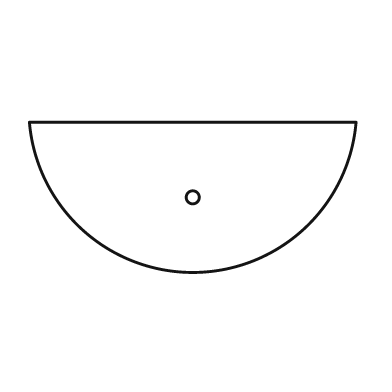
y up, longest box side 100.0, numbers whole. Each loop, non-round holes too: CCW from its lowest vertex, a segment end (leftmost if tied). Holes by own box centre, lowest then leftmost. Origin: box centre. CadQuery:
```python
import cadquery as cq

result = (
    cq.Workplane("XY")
    .moveTo(-50.0, 23.0)
    .threePointArc((0.0, -23.0), (50.0, 23.0))
    .close()
    .moveTo(0.0, 0.0)
    .circle(2.0)
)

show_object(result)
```